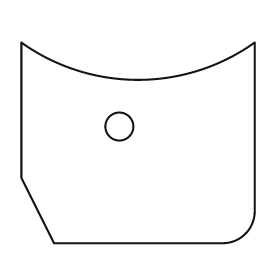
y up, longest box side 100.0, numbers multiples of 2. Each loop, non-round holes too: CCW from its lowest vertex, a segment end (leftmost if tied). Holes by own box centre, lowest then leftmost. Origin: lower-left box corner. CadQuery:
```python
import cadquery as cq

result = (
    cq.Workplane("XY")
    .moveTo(14.0, 0.0)
    .lineTo(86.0, 0.0)
    .threePointArc((96.0, 4.0), (100.0, 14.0))
    .lineTo(100.0, 86.0)
    .threePointArc((50.0, 70.0), (0.0, 86.0))
    .lineTo(0.0, 28.0)
    .close()
    .moveTo(42.0, 50.0)
    .circle(6.0)
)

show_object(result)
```